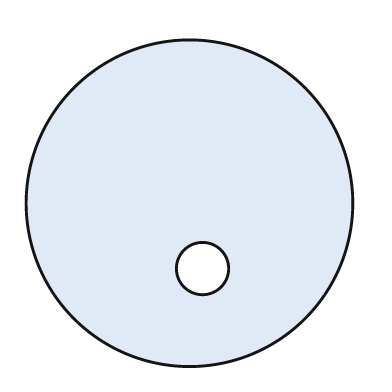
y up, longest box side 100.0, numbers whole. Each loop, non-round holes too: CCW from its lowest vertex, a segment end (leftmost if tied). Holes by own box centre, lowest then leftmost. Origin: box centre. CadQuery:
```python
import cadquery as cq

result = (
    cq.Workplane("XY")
    .moveTo(0.0, 0.0)
    .circle(50.0)
    .moveTo(4.0, -20.0)
    .circle(8.0)
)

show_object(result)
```